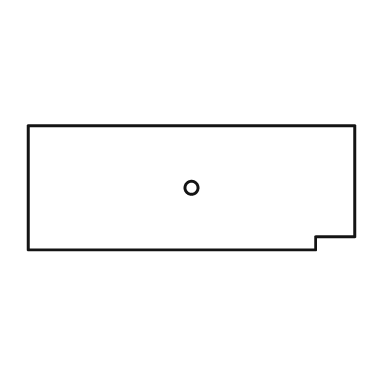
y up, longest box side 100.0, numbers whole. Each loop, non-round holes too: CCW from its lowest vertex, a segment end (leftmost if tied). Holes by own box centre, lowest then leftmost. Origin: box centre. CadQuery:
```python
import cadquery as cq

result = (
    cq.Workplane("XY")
    .moveTo(-50.0, -19.0)
    .lineTo(38.0, -19.0)
    .lineTo(38.0, -15.0)
    .lineTo(50.0, -15.0)
    .lineTo(50.0, 19.0)
    .lineTo(-50.0, 19.0)
    .close()
    .moveTo(0.0, 0.0)
    .circle(2.0)
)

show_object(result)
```